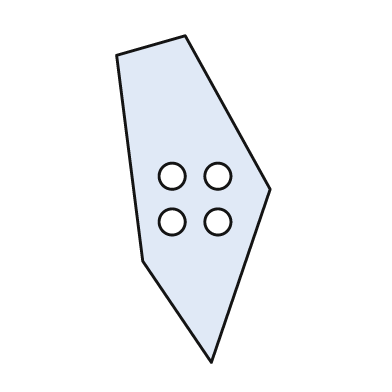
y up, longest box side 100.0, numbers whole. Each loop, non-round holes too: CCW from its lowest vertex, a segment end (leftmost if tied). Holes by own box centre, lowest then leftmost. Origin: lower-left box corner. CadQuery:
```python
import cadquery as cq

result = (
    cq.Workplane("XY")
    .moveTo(29.0, 0.0)
    .lineTo(47.0, 53.0)
    .lineTo(21.0, 100.0)
    .lineTo(0.0, 94.0)
    .lineTo(8.0, 31.0)
    .close()
    .moveTo(17.0, 43.0)
    .circle(4.0)
    .moveTo(31.0, 43.0)
    .circle(4.0)
    .moveTo(17.0, 57.0)
    .circle(4.0)
    .moveTo(31.0, 57.0)
    .circle(4.0)
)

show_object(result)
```